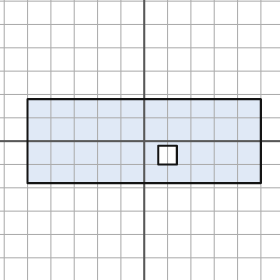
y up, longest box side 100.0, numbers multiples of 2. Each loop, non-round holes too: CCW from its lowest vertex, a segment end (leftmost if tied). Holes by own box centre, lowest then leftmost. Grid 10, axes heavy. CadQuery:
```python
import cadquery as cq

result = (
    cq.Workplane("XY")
    .moveTo(-50.0, -18.0)
    .lineTo(50.0, -18.0)
    .lineTo(50.0, 18.0)
    .lineTo(-50.0, 18.0)
    .close()
    .moveTo(6.0, -10.0)
    .lineTo(14.0, -10.0)
    .lineTo(14.0, -2.0)
    .lineTo(6.0, -2.0)
    .close()
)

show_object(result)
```